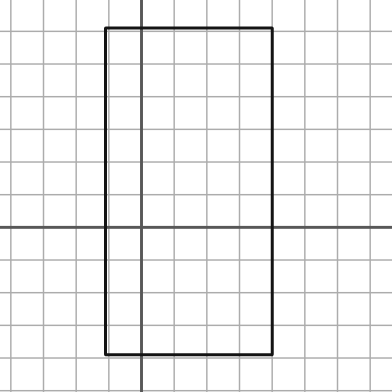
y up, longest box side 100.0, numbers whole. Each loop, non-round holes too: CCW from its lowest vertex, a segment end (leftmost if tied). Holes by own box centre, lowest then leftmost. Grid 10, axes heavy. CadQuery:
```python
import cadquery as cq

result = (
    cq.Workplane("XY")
    .moveTo(-11.0, -39.0)
    .lineTo(40.0, -39.0)
    .lineTo(40.0, 61.0)
    .lineTo(-11.0, 61.0)
    .close()
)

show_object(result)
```